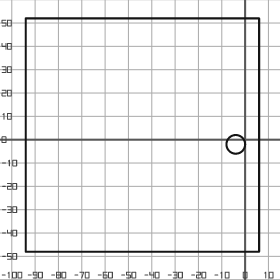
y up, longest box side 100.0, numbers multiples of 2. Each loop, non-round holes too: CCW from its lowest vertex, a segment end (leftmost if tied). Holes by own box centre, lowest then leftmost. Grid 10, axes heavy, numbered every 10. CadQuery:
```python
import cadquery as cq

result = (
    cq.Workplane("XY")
    .moveTo(-94.0, -48.0)
    .lineTo(6.0, -48.0)
    .lineTo(6.0, 52.0)
    .lineTo(-94.0, 52.0)
    .close()
    .moveTo(-4.0, -2.0)
    .circle(4.0)
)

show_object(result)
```